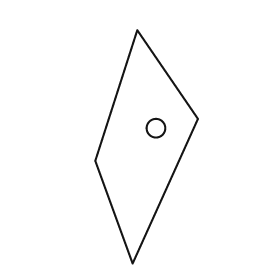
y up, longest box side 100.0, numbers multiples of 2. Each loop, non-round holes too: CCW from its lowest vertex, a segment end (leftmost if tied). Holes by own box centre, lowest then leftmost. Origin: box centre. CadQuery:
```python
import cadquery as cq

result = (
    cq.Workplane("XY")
    .moveTo(-6.0, -50.0)
    .lineTo(22.0, 12.0)
    .lineTo(-4.0, 50.0)
    .lineTo(-22.0, -6.0)
    .close()
    .moveTo(4.0, 8.0)
    .circle(4.0)
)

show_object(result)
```